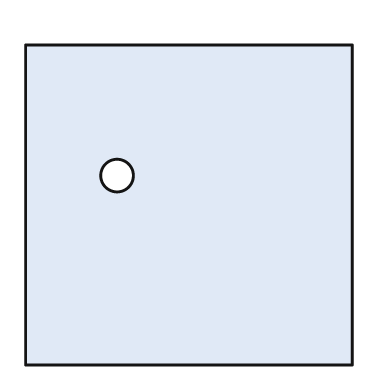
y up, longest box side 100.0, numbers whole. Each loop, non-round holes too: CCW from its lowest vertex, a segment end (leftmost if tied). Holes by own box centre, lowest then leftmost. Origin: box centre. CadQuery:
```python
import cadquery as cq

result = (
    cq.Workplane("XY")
    .moveTo(-50.0, -49.0)
    .lineTo(50.0, -49.0)
    .lineTo(50.0, 49.0)
    .lineTo(-50.0, 49.0)
    .close()
    .moveTo(-22.0, 9.0)
    .circle(5.0)
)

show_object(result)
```